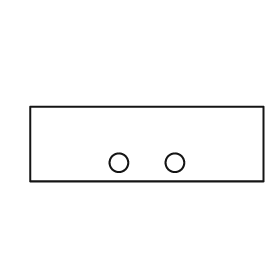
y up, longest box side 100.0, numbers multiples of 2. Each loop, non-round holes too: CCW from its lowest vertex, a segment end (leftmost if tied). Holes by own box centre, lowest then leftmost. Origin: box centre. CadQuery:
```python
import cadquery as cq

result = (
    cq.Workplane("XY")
    .moveTo(-50.0, -16.0)
    .lineTo(50.0, -16.0)
    .lineTo(50.0, 16.0)
    .lineTo(-50.0, 16.0)
    .close()
    .moveTo(-12.0, -8.0)
    .circle(4.0)
    .moveTo(12.0, -8.0)
    .circle(4.0)
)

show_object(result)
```